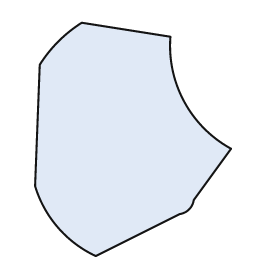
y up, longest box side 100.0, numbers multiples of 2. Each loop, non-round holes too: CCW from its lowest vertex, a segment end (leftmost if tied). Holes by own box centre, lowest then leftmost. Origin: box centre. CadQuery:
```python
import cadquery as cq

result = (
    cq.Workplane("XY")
    .moveTo(-16.0, -50.0)
    .lineTo(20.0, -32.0)
    .threePointArc((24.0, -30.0), (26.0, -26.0))
    .lineTo(42.0, -4.0)
    .threePointArc((22.0, 16.0), (16.0, 44.0))
    .lineTo(-22.0, 50.0)
    .threePointArc((-32.0, 42.0), (-40.0, 32.0))
    .lineTo(-42.0, -20.0)
    .threePointArc((-32.0, -38.0), (-16.0, -50.0))
    .close()
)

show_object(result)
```